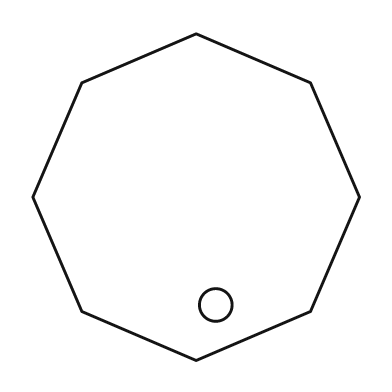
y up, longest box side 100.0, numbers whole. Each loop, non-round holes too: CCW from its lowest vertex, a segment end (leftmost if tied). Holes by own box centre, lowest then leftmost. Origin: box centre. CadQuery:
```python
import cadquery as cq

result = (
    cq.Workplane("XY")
    .moveTo(0.0, -50.0)
    .lineTo(35.0, -35.0)
    .lineTo(50.0, 0.0)
    .lineTo(35.0, 35.0)
    .lineTo(0.0, 50.0)
    .lineTo(-35.0, 35.0)
    .lineTo(-50.0, 0.0)
    .lineTo(-35.0, -35.0)
    .close()
    .moveTo(6.0, -33.0)
    .circle(5.0)
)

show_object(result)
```